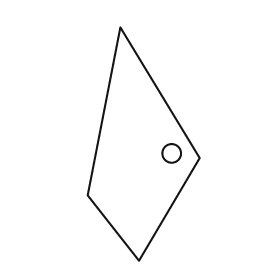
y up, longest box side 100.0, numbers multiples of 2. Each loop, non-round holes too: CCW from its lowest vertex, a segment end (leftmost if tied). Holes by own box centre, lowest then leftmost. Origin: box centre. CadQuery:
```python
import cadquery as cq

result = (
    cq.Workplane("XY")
    .moveTo(-2.0, -50.0)
    .lineTo(24.0, -6.0)
    .lineTo(-10.0, 50.0)
    .lineTo(-24.0, -22.0)
    .close()
    .moveTo(12.0, -4.0)
    .circle(4.0)
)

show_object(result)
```